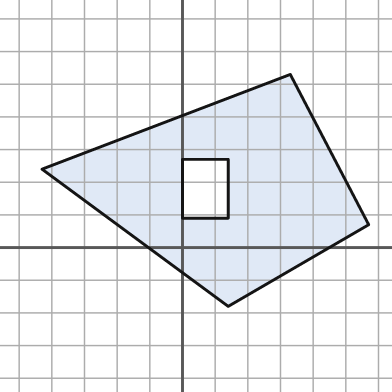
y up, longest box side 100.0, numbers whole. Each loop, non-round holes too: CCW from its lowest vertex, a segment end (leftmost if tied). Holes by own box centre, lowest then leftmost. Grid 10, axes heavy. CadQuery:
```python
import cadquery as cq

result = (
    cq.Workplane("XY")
    .moveTo(14.0, -18.0)
    .lineTo(57.0, 7.0)
    .lineTo(33.0, 53.0)
    .lineTo(-43.0, 24.0)
    .close()
    .moveTo(0.0, 9.0)
    .lineTo(14.0, 9.0)
    .lineTo(14.0, 27.0)
    .lineTo(0.0, 27.0)
    .close()
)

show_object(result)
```